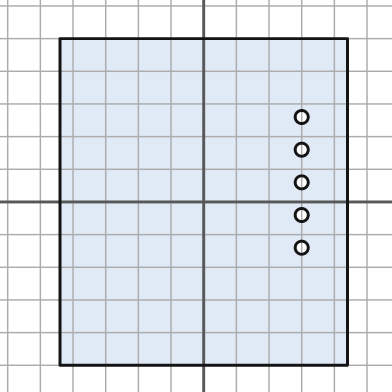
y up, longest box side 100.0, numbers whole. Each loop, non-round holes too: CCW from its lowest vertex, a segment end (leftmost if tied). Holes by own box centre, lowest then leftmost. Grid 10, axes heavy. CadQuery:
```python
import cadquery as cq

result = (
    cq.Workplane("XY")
    .moveTo(-44.0, -50.0)
    .lineTo(44.0, -50.0)
    .lineTo(44.0, 50.0)
    .lineTo(-44.0, 50.0)
    .close()
    .moveTo(30.0, -14.0)
    .circle(2.0)
    .moveTo(30.0, -4.0)
    .circle(2.0)
    .moveTo(30.0, 6.0)
    .circle(2.0)
    .moveTo(30.0, 16.0)
    .circle(2.0)
    .moveTo(30.0, 26.0)
    .circle(2.0)
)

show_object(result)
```